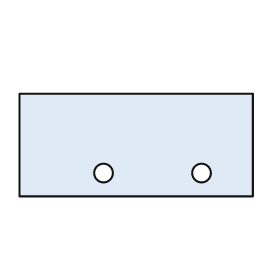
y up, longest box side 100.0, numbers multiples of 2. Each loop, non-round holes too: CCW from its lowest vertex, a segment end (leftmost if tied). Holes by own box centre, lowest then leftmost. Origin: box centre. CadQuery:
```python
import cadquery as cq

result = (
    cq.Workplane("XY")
    .moveTo(-50.0, -22.0)
    .lineTo(50.0, -22.0)
    .lineTo(50.0, 22.0)
    .lineTo(-50.0, 22.0)
    .close()
    .moveTo(-14.0, -12.0)
    .circle(4.0)
    .moveTo(28.0, -12.0)
    .circle(4.0)
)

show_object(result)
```